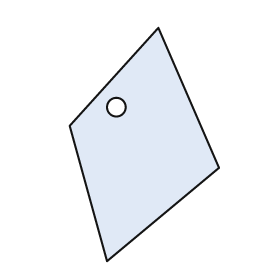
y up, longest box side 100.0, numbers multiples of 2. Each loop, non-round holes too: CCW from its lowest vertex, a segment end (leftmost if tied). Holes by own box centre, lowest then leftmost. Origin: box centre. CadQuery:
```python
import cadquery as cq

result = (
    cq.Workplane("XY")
    .moveTo(-16.0, -50.0)
    .lineTo(32.0, -10.0)
    .lineTo(6.0, 50.0)
    .lineTo(-32.0, 8.0)
    .close()
    .moveTo(-12.0, 16.0)
    .circle(4.0)
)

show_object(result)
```